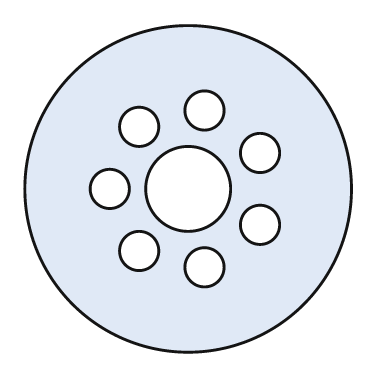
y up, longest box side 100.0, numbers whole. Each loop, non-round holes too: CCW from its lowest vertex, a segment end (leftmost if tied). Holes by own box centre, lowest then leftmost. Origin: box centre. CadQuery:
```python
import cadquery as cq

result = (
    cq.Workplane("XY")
    .moveTo(0.0, 0.0)
    .circle(50.0)
    .moveTo(5.0, -24.0)
    .circle(6.0)
    .moveTo(-15.0, -19.0)
    .circle(6.0)
    .moveTo(22.0, -11.0)
    .circle(6.0)
    .moveTo(-24.0, 0.0)
    .circle(6.0)
    .moveTo(0.0, 0.0)
    .circle(13.0)
    .moveTo(22.0, 11.0)
    .circle(6.0)
    .moveTo(-15.0, 19.0)
    .circle(6.0)
    .moveTo(5.0, 24.0)
    .circle(6.0)
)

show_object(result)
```